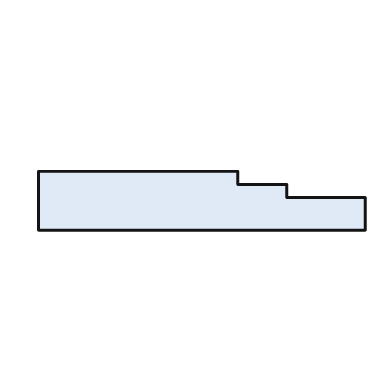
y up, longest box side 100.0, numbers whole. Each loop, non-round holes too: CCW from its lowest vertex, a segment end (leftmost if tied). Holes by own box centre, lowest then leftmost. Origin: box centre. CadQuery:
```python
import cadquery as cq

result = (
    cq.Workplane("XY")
    .moveTo(-50.0, -9.0)
    .lineTo(50.0, -9.0)
    .lineTo(50.0, 1.0)
    .lineTo(26.0, 1.0)
    .lineTo(26.0, 5.0)
    .lineTo(11.0, 5.0)
    .lineTo(11.0, 9.0)
    .lineTo(-50.0, 9.0)
    .close()
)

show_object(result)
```